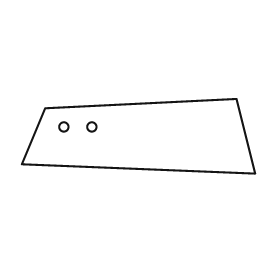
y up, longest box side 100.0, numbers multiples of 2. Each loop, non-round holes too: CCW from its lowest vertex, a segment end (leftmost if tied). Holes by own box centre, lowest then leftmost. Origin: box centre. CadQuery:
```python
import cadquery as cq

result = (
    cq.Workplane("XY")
    .moveTo(50.0, -16.0)
    .lineTo(42.0, 16.0)
    .lineTo(-40.0, 12.0)
    .lineTo(-50.0, -12.0)
    .close()
    .moveTo(-32.0, 4.0)
    .circle(2.0)
    .moveTo(-20.0, 4.0)
    .circle(2.0)
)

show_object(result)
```